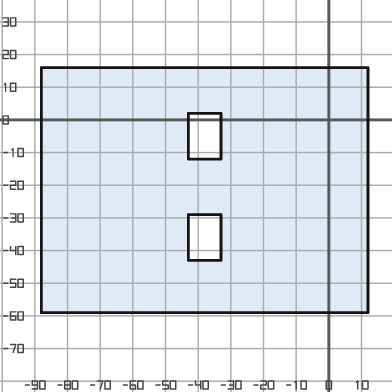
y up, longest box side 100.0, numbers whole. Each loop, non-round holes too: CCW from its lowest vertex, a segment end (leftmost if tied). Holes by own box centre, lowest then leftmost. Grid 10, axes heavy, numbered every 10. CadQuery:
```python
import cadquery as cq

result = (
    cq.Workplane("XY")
    .moveTo(-88.0, -59.0)
    .lineTo(12.0, -59.0)
    .lineTo(12.0, 16.0)
    .lineTo(-88.0, 16.0)
    .close()
    .moveTo(-43.0, -43.0)
    .lineTo(-33.0, -43.0)
    .lineTo(-33.0, -29.0)
    .lineTo(-43.0, -29.0)
    .close()
    .moveTo(-43.0, -12.0)
    .lineTo(-33.0, -12.0)
    .lineTo(-33.0, 2.0)
    .lineTo(-43.0, 2.0)
    .close()
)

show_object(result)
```